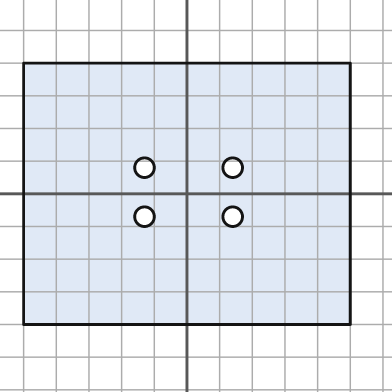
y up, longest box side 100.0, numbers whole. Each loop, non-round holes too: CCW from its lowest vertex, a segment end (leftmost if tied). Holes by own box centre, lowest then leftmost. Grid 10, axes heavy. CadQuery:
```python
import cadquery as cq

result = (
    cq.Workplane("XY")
    .moveTo(-50.0, -40.0)
    .lineTo(50.0, -40.0)
    .lineTo(50.0, 40.0)
    .lineTo(-50.0, 40.0)
    .close()
    .moveTo(-13.0, -7.0)
    .circle(3.0)
    .moveTo(14.0, -7.0)
    .circle(3.0)
    .moveTo(-13.0, 8.0)
    .circle(3.0)
    .moveTo(14.0, 8.0)
    .circle(3.0)
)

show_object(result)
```